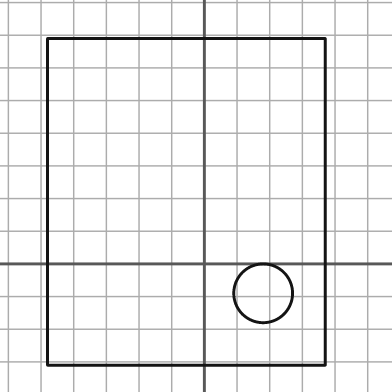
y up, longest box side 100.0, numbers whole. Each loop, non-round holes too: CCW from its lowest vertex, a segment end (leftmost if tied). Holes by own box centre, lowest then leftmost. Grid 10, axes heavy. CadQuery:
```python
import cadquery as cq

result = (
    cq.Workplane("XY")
    .moveTo(-48.0, -31.0)
    .lineTo(37.0, -31.0)
    .lineTo(37.0, 69.0)
    .lineTo(-48.0, 69.0)
    .close()
    .moveTo(18.0, -9.0)
    .circle(9.0)
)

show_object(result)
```